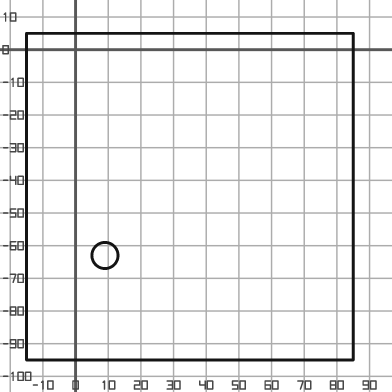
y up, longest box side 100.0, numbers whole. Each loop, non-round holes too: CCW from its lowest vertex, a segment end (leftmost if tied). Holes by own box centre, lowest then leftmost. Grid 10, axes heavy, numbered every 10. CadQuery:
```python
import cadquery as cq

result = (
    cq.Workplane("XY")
    .moveTo(-15.0, -95.0)
    .lineTo(85.0, -95.0)
    .lineTo(85.0, 5.0)
    .lineTo(-15.0, 5.0)
    .close()
    .moveTo(9.0, -63.0)
    .circle(4.0)
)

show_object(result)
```